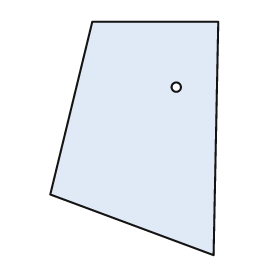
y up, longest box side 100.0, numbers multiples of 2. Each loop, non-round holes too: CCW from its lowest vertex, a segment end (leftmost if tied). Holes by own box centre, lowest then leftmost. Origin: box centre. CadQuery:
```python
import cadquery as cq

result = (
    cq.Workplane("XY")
    .moveTo(34.0, -50.0)
    .lineTo(36.0, 50.0)
    .lineTo(-18.0, 50.0)
    .lineTo(-36.0, -24.0)
    .close()
    .moveTo(18.0, 22.0)
    .circle(2.0)
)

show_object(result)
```